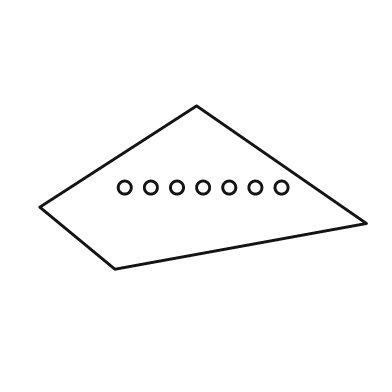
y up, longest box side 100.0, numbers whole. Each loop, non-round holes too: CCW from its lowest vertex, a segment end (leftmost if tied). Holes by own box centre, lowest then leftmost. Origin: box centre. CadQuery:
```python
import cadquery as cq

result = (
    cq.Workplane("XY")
    .moveTo(-27.0, -25.0)
    .lineTo(50.0, -11.0)
    .lineTo(-2.0, 25.0)
    .lineTo(-50.0, -6.0)
    .close()
    .moveTo(-24.0, 0.0)
    .circle(2.0)
    .moveTo(-16.0, 0.0)
    .circle(2.0)
    .moveTo(-8.0, 0.0)
    .circle(2.0)
    .moveTo(0.0, 0.0)
    .circle(2.0)
    .moveTo(8.0, 0.0)
    .circle(2.0)
    .moveTo(16.0, 0.0)
    .circle(2.0)
    .moveTo(24.0, 0.0)
    .circle(2.0)
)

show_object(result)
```